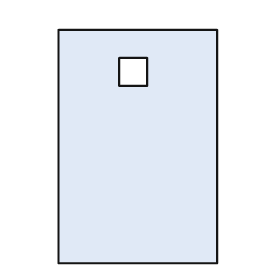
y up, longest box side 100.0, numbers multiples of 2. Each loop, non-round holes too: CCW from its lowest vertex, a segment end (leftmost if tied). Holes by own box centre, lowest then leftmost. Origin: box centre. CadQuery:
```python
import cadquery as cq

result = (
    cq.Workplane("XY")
    .moveTo(-34.0, -50.0)
    .lineTo(34.0, -50.0)
    .lineTo(34.0, 50.0)
    .lineTo(-34.0, 50.0)
    .close()
    .moveTo(-8.0, 26.0)
    .lineTo(4.0, 26.0)
    .lineTo(4.0, 38.0)
    .lineTo(-8.0, 38.0)
    .close()
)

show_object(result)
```